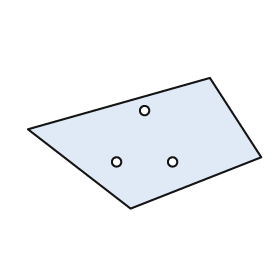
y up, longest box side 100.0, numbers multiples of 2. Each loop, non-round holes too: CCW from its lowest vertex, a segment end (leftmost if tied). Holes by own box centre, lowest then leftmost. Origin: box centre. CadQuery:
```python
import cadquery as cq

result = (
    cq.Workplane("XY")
    .moveTo(-6.0, -28.0)
    .lineTo(50.0, -6.0)
    .lineTo(28.0, 28.0)
    .lineTo(-50.0, 6.0)
    .close()
    .moveTo(-12.0, -8.0)
    .circle(2.0)
    .moveTo(12.0, -8.0)
    .circle(2.0)
    .moveTo(0.0, 14.0)
    .circle(2.0)
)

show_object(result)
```